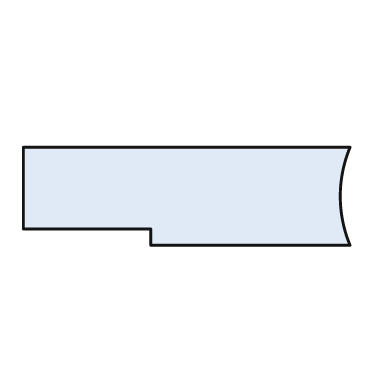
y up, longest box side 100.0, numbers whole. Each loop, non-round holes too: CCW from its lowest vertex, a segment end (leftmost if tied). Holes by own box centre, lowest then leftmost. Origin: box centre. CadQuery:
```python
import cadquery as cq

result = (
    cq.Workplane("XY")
    .moveTo(-11.0, -15.0)
    .lineTo(50.0, -15.0)
    .threePointArc((47.0, 0.0), (50.0, 15.0))
    .lineTo(-50.0, 15.0)
    .lineTo(-50.0, -10.0)
    .lineTo(-11.0, -10.0)
    .close()
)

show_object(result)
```